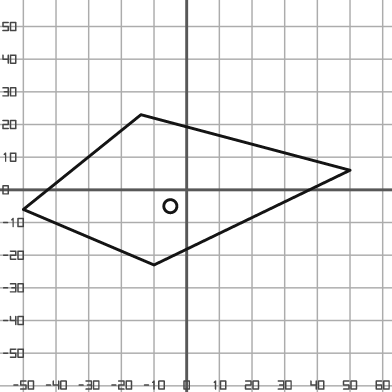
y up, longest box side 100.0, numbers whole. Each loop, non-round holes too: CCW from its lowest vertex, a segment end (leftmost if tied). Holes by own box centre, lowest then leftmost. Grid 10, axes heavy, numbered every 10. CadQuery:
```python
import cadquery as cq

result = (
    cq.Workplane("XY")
    .moveTo(-10.0, -23.0)
    .lineTo(50.0, 6.0)
    .lineTo(-14.0, 23.0)
    .lineTo(-50.0, -6.0)
    .close()
    .moveTo(-5.0, -5.0)
    .circle(2.0)
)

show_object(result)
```